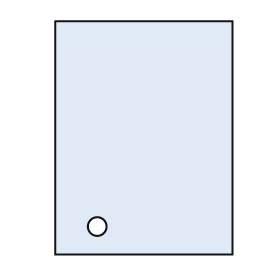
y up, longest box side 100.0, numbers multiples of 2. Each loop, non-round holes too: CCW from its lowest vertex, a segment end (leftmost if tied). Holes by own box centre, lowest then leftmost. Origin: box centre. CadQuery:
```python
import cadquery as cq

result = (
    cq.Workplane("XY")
    .moveTo(-38.0, -50.0)
    .lineTo(38.0, -50.0)
    .lineTo(38.0, 50.0)
    .lineTo(-38.0, 50.0)
    .close()
    .moveTo(-20.0, -38.0)
    .circle(4.0)
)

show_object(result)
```